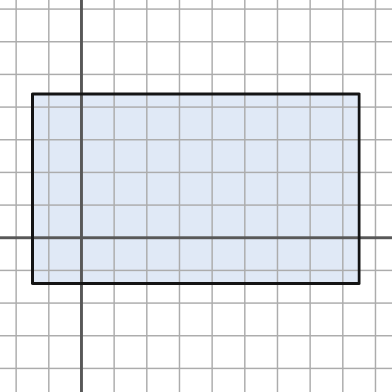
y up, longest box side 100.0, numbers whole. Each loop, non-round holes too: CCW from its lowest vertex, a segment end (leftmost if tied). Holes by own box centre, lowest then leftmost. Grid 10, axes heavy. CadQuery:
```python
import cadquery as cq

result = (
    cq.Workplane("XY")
    .moveTo(-15.0, -14.0)
    .lineTo(85.0, -14.0)
    .lineTo(85.0, 44.0)
    .lineTo(-15.0, 44.0)
    .close()
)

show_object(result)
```